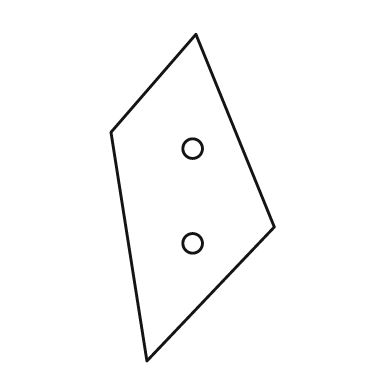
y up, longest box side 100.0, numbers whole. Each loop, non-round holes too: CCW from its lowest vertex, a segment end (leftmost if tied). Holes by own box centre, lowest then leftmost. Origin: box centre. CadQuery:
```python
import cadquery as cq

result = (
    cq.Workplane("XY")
    .moveTo(-14.0, -50.0)
    .lineTo(25.0, -9.0)
    .lineTo(1.0, 50.0)
    .lineTo(-25.0, 20.0)
    .close()
    .moveTo(0.0, -14.0)
    .circle(3.0)
    .moveTo(0.0, 15.0)
    .circle(3.0)
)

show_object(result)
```